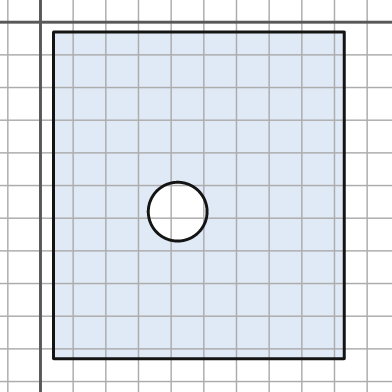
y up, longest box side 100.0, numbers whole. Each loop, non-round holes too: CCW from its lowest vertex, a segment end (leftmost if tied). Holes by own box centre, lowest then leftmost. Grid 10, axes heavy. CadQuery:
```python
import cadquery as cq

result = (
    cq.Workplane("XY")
    .moveTo(4.0, -103.0)
    .lineTo(93.0, -103.0)
    .lineTo(93.0, -3.0)
    .lineTo(4.0, -3.0)
    .close()
    .moveTo(42.0, -58.0)
    .circle(9.0)
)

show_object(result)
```